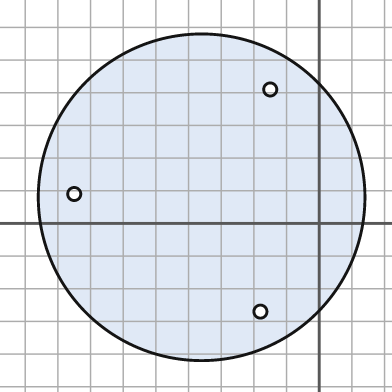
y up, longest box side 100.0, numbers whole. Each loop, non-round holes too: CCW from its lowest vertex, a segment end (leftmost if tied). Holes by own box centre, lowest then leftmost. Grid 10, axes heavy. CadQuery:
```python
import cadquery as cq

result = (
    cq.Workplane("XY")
    .moveTo(-36.0, 8.0)
    .circle(50.0)
    .moveTo(-18.0, -27.0)
    .circle(2.0)
    .moveTo(-75.0, 9.0)
    .circle(2.0)
    .moveTo(-15.0, 41.0)
    .circle(2.0)
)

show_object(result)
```